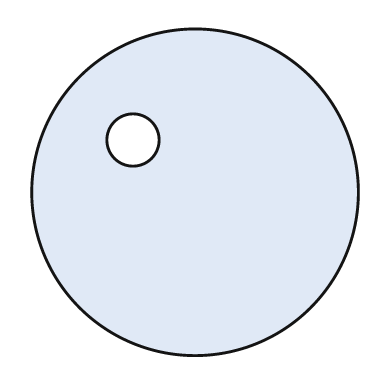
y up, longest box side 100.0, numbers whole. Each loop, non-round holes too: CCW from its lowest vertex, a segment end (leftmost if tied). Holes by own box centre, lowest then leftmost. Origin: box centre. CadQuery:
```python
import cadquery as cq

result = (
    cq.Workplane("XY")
    .moveTo(0.0, 0.0)
    .circle(50.0)
    .moveTo(-19.0, 16.0)
    .circle(8.0)
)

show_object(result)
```